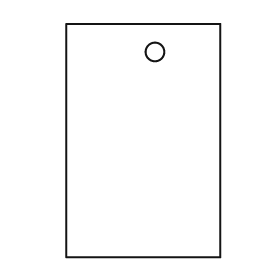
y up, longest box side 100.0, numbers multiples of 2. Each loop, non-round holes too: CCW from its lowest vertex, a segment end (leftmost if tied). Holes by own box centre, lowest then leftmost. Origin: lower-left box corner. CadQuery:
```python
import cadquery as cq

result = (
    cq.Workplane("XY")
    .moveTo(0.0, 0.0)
    .lineTo(66.0, 0.0)
    .lineTo(66.0, 100.0)
    .lineTo(0.0, 100.0)
    .close()
    .moveTo(38.0, 88.0)
    .circle(4.0)
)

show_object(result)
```